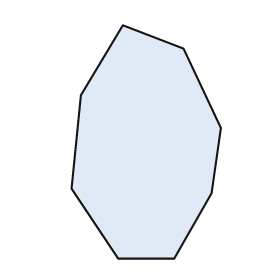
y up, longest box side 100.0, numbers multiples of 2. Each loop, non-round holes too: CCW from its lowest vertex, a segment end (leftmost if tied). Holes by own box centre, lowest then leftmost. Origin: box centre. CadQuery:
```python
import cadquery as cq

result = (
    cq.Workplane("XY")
    .moveTo(-12.0, -50.0)
    .lineTo(12.0, -50.0)
    .lineTo(28.0, -22.0)
    .lineTo(32.0, 6.0)
    .lineTo(16.0, 40.0)
    .lineTo(-10.0, 50.0)
    .lineTo(-28.0, 20.0)
    .lineTo(-32.0, -20.0)
    .close()
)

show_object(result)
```